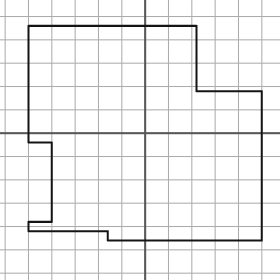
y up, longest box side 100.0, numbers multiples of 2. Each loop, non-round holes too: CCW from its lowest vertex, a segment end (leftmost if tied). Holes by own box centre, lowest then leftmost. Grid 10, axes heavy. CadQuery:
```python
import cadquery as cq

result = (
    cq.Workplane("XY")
    .moveTo(-16.0, -46.0)
    .lineTo(50.0, -46.0)
    .lineTo(50.0, 18.0)
    .lineTo(22.0, 18.0)
    .lineTo(22.0, 46.0)
    .lineTo(-50.0, 46.0)
    .lineTo(-50.0, -4.0)
    .lineTo(-40.0, -4.0)
    .lineTo(-40.0, -38.0)
    .lineTo(-50.0, -38.0)
    .lineTo(-50.0, -42.0)
    .lineTo(-16.0, -42.0)
    .close()
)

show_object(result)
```